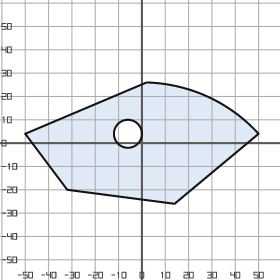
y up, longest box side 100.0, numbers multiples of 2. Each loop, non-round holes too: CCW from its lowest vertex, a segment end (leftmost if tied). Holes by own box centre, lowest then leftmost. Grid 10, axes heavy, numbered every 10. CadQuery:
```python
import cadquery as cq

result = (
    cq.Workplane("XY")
    .moveTo(14.0, -26.0)
    .lineTo(50.0, 4.0)
    .threePointArc((28.0, 20.0), (2.0, 26.0))
    .lineTo(-50.0, 4.0)
    .lineTo(-32.0, -20.0)
    .close()
    .moveTo(-6.0, 4.0)
    .circle(6.0)
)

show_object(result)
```